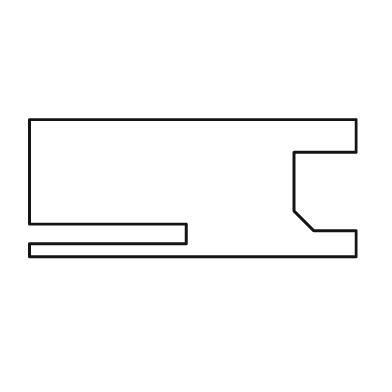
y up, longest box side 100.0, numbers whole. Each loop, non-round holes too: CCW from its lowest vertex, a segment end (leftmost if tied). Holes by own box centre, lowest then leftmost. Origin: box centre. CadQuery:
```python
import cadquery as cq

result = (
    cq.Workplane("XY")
    .moveTo(-50.0, -21.0)
    .lineTo(50.0, -21.0)
    .lineTo(50.0, -13.0)
    .lineTo(37.0, -13.0)
    .lineTo(31.0, -7.0)
    .lineTo(31.0, 11.0)
    .lineTo(50.0, 11.0)
    .lineTo(50.0, 21.0)
    .lineTo(-50.0, 21.0)
    .lineTo(-50.0, -11.0)
    .lineTo(-2.0, -11.0)
    .lineTo(-2.0, -17.0)
    .lineTo(-50.0, -17.0)
    .close()
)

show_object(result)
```